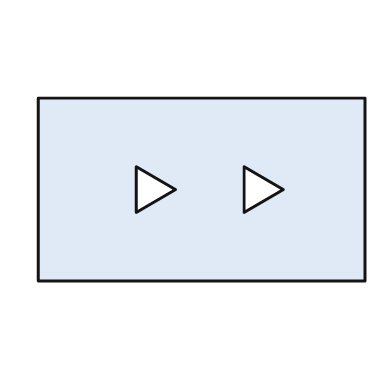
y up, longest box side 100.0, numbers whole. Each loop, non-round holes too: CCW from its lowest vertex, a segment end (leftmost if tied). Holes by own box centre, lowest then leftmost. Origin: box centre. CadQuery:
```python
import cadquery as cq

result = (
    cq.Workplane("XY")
    .moveTo(-50.0, -28.0)
    .lineTo(50.0, -28.0)
    .lineTo(50.0, 28.0)
    .lineTo(-50.0, 28.0)
    .close()
    .moveTo(-20.0, -7.0)
    .lineTo(-8.0, 0.0)
    .lineTo(-20.0, 7.0)
    .close()
    .moveTo(13.0, -7.0)
    .lineTo(25.0, 0.0)
    .lineTo(13.0, 7.0)
    .close()
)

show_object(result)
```